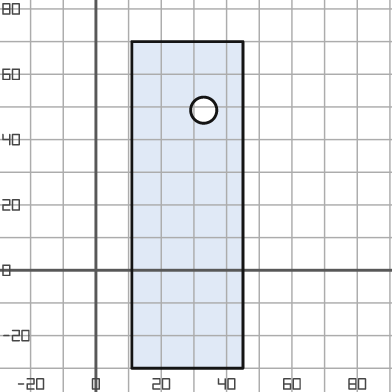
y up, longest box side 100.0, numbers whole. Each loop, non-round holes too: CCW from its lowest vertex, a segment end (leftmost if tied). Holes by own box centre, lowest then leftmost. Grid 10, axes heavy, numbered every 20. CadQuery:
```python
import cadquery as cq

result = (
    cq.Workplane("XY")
    .moveTo(11.0, -30.0)
    .lineTo(45.0, -30.0)
    .lineTo(45.0, 70.0)
    .lineTo(11.0, 70.0)
    .close()
    .moveTo(33.0, 49.0)
    .circle(4.0)
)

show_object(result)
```